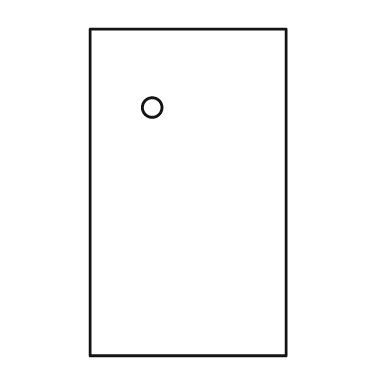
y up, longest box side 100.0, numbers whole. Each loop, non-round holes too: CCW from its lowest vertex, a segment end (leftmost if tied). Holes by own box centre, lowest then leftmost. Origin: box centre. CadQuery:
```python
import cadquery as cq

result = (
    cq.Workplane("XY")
    .moveTo(-30.0, -50.0)
    .lineTo(30.0, -50.0)
    .lineTo(30.0, 50.0)
    .lineTo(-30.0, 50.0)
    .close()
    .moveTo(-11.0, 26.0)
    .circle(3.0)
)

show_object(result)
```